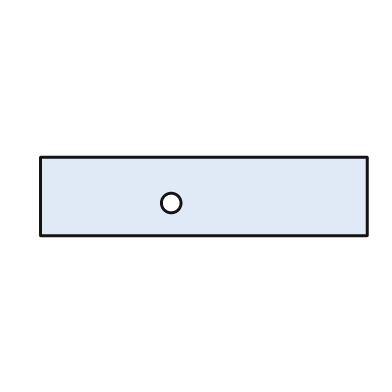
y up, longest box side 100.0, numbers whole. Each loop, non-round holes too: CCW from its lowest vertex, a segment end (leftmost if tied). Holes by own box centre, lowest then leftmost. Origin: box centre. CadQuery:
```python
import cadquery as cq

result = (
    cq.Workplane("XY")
    .moveTo(-50.0, -12.0)
    .lineTo(50.0, -12.0)
    .lineTo(50.0, 12.0)
    .lineTo(-50.0, 12.0)
    .close()
    .moveTo(-10.0, -2.0)
    .circle(3.0)
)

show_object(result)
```